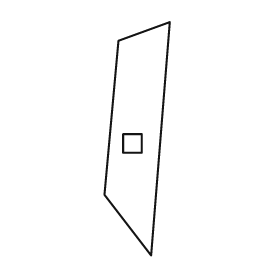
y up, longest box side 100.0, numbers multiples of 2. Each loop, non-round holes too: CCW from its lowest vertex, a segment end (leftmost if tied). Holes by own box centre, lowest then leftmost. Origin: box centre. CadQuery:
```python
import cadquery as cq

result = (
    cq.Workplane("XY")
    .moveTo(6.0, -50.0)
    .lineTo(14.0, 50.0)
    .lineTo(-8.0, 42.0)
    .lineTo(-14.0, -24.0)
    .close()
    .moveTo(-6.0, -6.0)
    .lineTo(2.0, -6.0)
    .lineTo(2.0, 2.0)
    .lineTo(-6.0, 2.0)
    .close()
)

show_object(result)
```